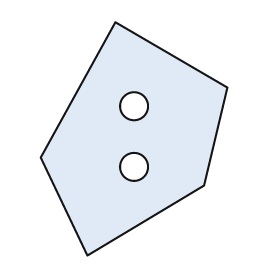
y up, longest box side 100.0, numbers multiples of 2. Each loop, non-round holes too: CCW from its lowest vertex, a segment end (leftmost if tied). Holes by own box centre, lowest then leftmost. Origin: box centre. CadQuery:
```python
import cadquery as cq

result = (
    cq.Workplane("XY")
    .moveTo(-20.0, -50.0)
    .lineTo(30.0, -20.0)
    .lineTo(40.0, 22.0)
    .lineTo(-8.0, 50.0)
    .lineTo(-40.0, -8.0)
    .close()
    .moveTo(0.0, -12.0)
    .circle(6.0)
    .moveTo(0.0, 14.0)
    .circle(6.0)
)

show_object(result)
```